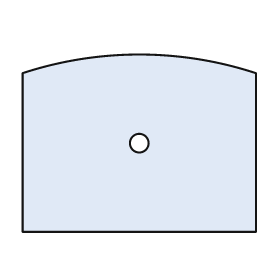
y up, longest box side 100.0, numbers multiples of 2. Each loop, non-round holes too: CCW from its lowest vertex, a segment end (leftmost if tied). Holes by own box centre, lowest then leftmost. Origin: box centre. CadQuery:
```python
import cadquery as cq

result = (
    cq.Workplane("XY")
    .moveTo(-50.0, -38.0)
    .lineTo(50.0, -38.0)
    .lineTo(50.0, 30.0)
    .threePointArc((0.0, 38.0), (-50.0, 30.0))
    .close()
    .moveTo(0.0, 0.0)
    .circle(4.0)
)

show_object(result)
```